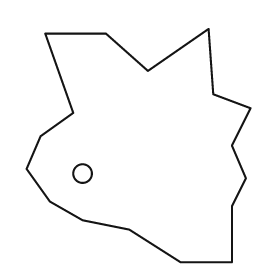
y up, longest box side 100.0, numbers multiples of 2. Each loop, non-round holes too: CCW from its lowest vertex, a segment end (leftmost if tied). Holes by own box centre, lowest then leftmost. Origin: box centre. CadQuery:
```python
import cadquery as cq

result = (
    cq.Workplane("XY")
    .moveTo(18.0, -50.0)
    .lineTo(40.0, -50.0)
    .lineTo(40.0, -26.0)
    .lineTo(46.0, -14.0)
    .lineTo(40.0, 0.0)
    .lineTo(48.0, 16.0)
    .lineTo(32.0, 22.0)
    .lineTo(30.0, 50.0)
    .lineTo(4.0, 32.0)
    .lineTo(-14.0, 48.0)
    .lineTo(-40.0, 48.0)
    .lineTo(-28.0, 14.0)
    .lineTo(-42.0, 4.0)
    .lineTo(-48.0, -10.0)
    .lineTo(-38.0, -24.0)
    .lineTo(-24.0, -32.0)
    .lineTo(-4.0, -36.0)
    .close()
    .moveTo(-24.0, -12.0)
    .circle(4.0)
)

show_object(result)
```